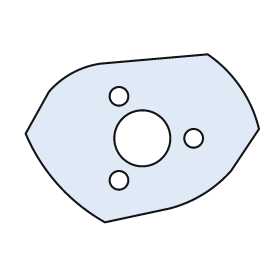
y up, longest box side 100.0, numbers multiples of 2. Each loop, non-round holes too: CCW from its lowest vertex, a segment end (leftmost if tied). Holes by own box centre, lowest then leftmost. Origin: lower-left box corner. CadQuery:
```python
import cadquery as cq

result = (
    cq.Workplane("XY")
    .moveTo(34.0, 0.0)
    .lineTo(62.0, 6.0)
    .threePointArc((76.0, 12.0), (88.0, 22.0))
    .lineTo(100.0, 40.0)
    .threePointArc((92.0, 58.0), (78.0, 72.0))
    .lineTo(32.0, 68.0)
    .threePointArc((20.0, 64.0), (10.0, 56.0))
    .lineTo(0.0, 38.0)
    .threePointArc((14.0, 16.0), (34.0, 0.0))
    .close()
    .moveTo(40.0, 18.0)
    .circle(4.0)
    .moveTo(50.0, 36.0)
    .circle(12.0)
    .moveTo(72.0, 36.0)
    .circle(4.0)
    .moveTo(40.0, 54.0)
    .circle(4.0)
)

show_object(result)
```